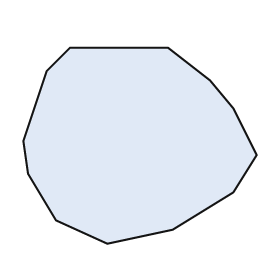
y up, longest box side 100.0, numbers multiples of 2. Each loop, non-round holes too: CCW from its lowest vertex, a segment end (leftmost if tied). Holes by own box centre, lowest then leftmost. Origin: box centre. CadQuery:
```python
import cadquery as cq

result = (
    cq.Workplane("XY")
    .moveTo(-14.0, -42.0)
    .lineTo(14.0, -36.0)
    .lineTo(40.0, -20.0)
    .lineTo(50.0, -4.0)
    .lineTo(40.0, 16.0)
    .lineTo(30.0, 28.0)
    .lineTo(12.0, 42.0)
    .lineTo(-30.0, 42.0)
    .lineTo(-40.0, 32.0)
    .lineTo(-50.0, 2.0)
    .lineTo(-48.0, -12.0)
    .lineTo(-36.0, -32.0)
    .close()
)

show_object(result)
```